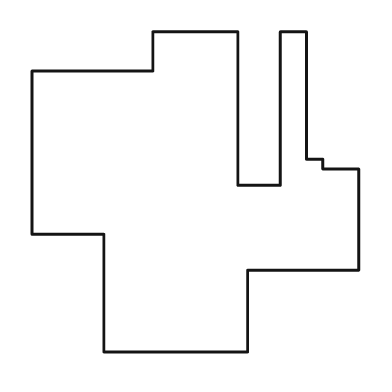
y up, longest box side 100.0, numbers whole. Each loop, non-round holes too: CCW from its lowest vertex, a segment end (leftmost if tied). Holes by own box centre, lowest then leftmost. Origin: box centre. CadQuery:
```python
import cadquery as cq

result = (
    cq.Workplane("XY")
    .moveTo(-28.0, -49.0)
    .lineTo(16.0, -49.0)
    .lineTo(16.0, -24.0)
    .lineTo(50.0, -24.0)
    .lineTo(50.0, 7.0)
    .lineTo(39.0, 7.0)
    .lineTo(39.0, 10.0)
    .lineTo(34.0, 10.0)
    .lineTo(34.0, 49.0)
    .lineTo(26.0, 49.0)
    .lineTo(26.0, 2.0)
    .lineTo(13.0, 2.0)
    .lineTo(13.0, 49.0)
    .lineTo(-13.0, 49.0)
    .lineTo(-13.0, 37.0)
    .lineTo(-50.0, 37.0)
    .lineTo(-50.0, -13.0)
    .lineTo(-28.0, -13.0)
    .close()
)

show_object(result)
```